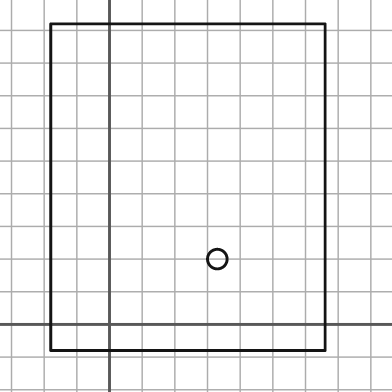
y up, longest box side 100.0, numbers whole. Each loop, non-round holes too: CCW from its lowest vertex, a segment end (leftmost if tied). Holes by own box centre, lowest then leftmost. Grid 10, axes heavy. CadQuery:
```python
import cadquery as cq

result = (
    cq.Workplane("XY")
    .moveTo(-18.0, -8.0)
    .lineTo(66.0, -8.0)
    .lineTo(66.0, 92.0)
    .lineTo(-18.0, 92.0)
    .close()
    .moveTo(33.0, 20.0)
    .circle(3.0)
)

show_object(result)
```